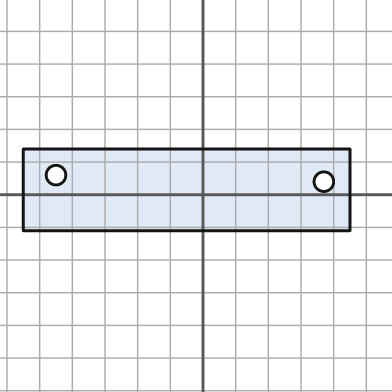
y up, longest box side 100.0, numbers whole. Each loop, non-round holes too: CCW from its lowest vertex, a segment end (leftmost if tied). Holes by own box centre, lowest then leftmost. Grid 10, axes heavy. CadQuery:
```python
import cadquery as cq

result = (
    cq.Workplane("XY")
    .moveTo(-55.0, -11.0)
    .lineTo(45.0, -11.0)
    .lineTo(45.0, 14.0)
    .lineTo(-55.0, 14.0)
    .close()
    .moveTo(37.0, 4.0)
    .circle(3.0)
    .moveTo(-45.0, 6.0)
    .circle(3.0)
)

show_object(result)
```